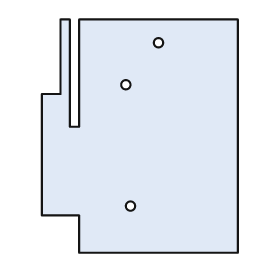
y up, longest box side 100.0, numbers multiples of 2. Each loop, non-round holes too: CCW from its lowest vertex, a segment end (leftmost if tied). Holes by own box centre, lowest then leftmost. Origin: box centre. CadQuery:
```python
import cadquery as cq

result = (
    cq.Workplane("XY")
    .moveTo(-26.0, -50.0)
    .lineTo(42.0, -50.0)
    .lineTo(42.0, 50.0)
    .lineTo(-26.0, 50.0)
    .lineTo(-26.0, 4.0)
    .lineTo(-30.0, 4.0)
    .lineTo(-30.0, 50.0)
    .lineTo(-34.0, 50.0)
    .lineTo(-34.0, 18.0)
    .lineTo(-42.0, 18.0)
    .lineTo(-42.0, -34.0)
    .lineTo(-26.0, -34.0)
    .close()
    .moveTo(-4.0, -30.0)
    .circle(2.0)
    .moveTo(-6.0, 22.0)
    .circle(2.0)
    .moveTo(8.0, 40.0)
    .circle(2.0)
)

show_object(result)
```